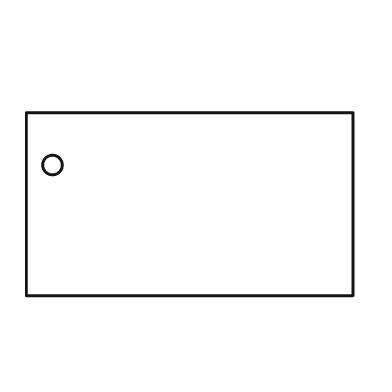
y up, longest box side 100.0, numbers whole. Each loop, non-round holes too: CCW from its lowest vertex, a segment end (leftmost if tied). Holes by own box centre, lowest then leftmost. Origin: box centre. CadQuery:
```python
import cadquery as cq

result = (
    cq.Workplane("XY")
    .moveTo(-50.0, -28.0)
    .lineTo(50.0, -28.0)
    .lineTo(50.0, 28.0)
    .lineTo(-50.0, 28.0)
    .close()
    .moveTo(-42.0, 12.0)
    .circle(3.0)
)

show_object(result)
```